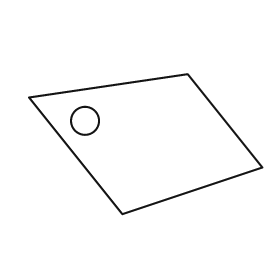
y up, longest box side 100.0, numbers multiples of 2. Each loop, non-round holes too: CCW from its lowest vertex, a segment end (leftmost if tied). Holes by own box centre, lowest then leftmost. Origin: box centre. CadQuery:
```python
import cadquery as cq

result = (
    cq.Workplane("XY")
    .moveTo(-10.0, -30.0)
    .lineTo(50.0, -10.0)
    .lineTo(18.0, 30.0)
    .lineTo(-50.0, 20.0)
    .close()
    .moveTo(-26.0, 10.0)
    .circle(6.0)
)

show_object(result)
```